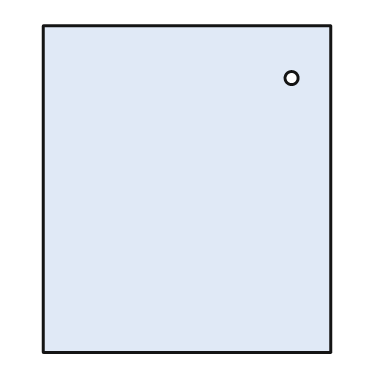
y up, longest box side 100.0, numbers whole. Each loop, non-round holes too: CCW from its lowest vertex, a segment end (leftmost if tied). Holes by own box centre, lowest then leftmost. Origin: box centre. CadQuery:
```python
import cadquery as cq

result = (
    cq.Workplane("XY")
    .moveTo(-44.0, -50.0)
    .lineTo(44.0, -50.0)
    .lineTo(44.0, 50.0)
    .lineTo(-44.0, 50.0)
    .close()
    .moveTo(32.0, 34.0)
    .circle(2.0)
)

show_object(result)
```